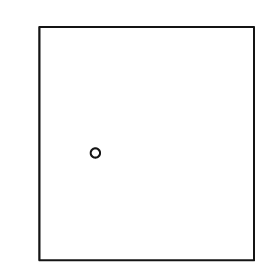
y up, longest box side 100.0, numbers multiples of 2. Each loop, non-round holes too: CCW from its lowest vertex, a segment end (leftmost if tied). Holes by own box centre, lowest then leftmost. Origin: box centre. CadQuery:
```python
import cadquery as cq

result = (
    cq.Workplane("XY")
    .moveTo(-46.0, -50.0)
    .lineTo(46.0, -50.0)
    .lineTo(46.0, 50.0)
    .lineTo(-46.0, 50.0)
    .close()
    .moveTo(-22.0, -4.0)
    .circle(2.0)
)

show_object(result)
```